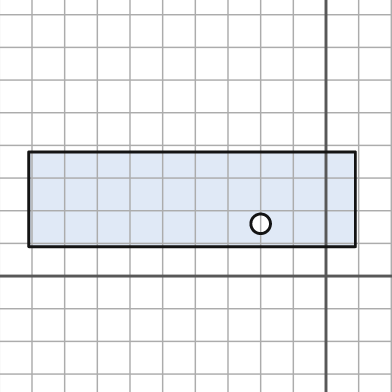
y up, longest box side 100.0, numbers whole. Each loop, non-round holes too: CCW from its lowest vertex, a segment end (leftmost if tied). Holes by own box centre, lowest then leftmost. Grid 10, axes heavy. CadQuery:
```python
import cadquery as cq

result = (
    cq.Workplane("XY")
    .moveTo(-91.0, 9.0)
    .lineTo(9.0, 9.0)
    .lineTo(9.0, 38.0)
    .lineTo(-91.0, 38.0)
    .close()
    .moveTo(-20.0, 16.0)
    .circle(3.0)
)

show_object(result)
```